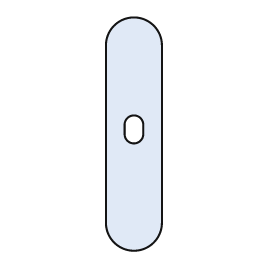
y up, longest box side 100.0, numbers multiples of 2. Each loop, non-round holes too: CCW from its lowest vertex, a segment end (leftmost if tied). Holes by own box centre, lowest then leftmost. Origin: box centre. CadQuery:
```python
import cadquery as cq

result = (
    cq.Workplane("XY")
    .moveTo(-12.0, -38.0)
    .threePointArc((0.0, -50.0), (12.0, -38.0))
    .lineTo(12.0, 38.0)
    .threePointArc((0.0, 50.0), (-12.0, 38.0))
    .close()
    .moveTo(-4.0, 0.0)
    .threePointArc((0.0, -4.0), (4.0, 0.0))
    .lineTo(4.0, 4.0)
    .threePointArc((0.0, 8.0), (-4.0, 4.0))
    .close()
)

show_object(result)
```